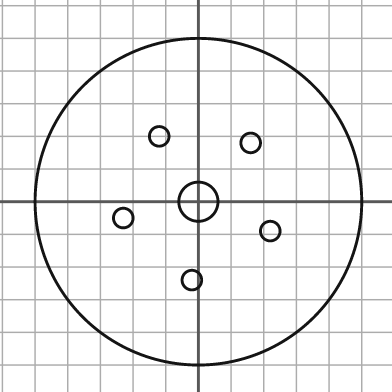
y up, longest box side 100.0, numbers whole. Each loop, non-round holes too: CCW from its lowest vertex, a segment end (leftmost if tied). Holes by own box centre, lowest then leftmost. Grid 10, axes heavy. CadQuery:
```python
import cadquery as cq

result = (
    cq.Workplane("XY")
    .moveTo(0.0, 0.0)
    .circle(50.0)
    .moveTo(-2.0, -24.0)
    .circle(3.0)
    .moveTo(22.0, -9.0)
    .circle(3.0)
    .moveTo(-23.0, -5.0)
    .circle(3.0)
    .moveTo(0.0, 0.0)
    .circle(6.0)
    .moveTo(16.0, 18.0)
    .circle(3.0)
    .moveTo(-12.0, 20.0)
    .circle(3.0)
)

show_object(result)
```